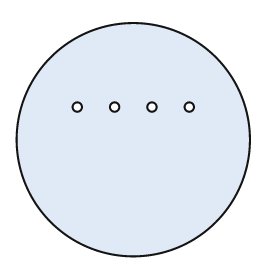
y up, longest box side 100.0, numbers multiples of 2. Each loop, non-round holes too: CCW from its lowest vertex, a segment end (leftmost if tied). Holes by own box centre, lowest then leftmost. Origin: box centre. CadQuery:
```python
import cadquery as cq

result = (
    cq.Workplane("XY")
    .moveTo(0.0, 0.0)
    .circle(50.0)
    .moveTo(-24.0, 14.0)
    .circle(2.0)
    .moveTo(-8.0, 14.0)
    .circle(2.0)
    .moveTo(8.0, 14.0)
    .circle(2.0)
    .moveTo(24.0, 14.0)
    .circle(2.0)
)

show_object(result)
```